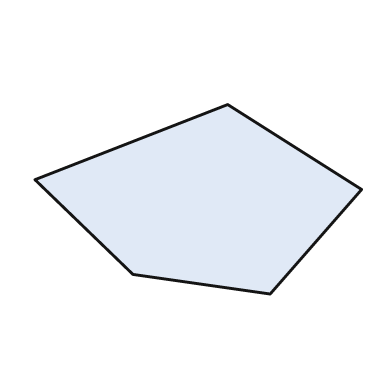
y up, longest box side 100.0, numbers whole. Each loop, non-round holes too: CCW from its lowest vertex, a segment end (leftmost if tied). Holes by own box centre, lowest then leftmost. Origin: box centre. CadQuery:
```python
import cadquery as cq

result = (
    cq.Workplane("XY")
    .moveTo(22.0, -29.0)
    .lineTo(50.0, 3.0)
    .lineTo(9.0, 29.0)
    .lineTo(-50.0, 6.0)
    .lineTo(-20.0, -23.0)
    .close()
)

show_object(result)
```